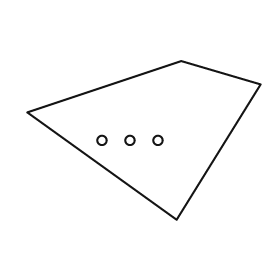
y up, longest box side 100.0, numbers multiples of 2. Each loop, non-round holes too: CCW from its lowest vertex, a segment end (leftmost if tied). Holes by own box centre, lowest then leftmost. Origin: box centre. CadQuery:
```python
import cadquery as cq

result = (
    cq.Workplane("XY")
    .moveTo(14.0, -34.0)
    .lineTo(50.0, 24.0)
    .lineTo(16.0, 34.0)
    .lineTo(-50.0, 12.0)
    .close()
    .moveTo(-18.0, 0.0)
    .circle(2.0)
    .moveTo(-6.0, 0.0)
    .circle(2.0)
    .moveTo(6.0, 0.0)
    .circle(2.0)
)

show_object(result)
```